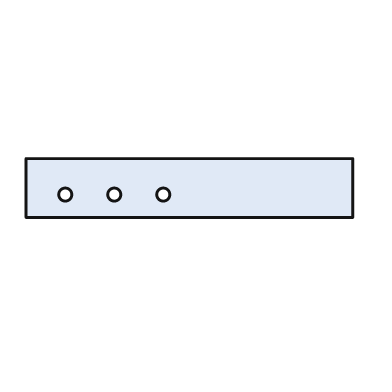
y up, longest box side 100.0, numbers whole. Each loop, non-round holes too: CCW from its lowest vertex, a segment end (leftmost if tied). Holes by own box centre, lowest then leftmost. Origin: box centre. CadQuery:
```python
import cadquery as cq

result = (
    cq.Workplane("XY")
    .moveTo(-50.0, -9.0)
    .lineTo(50.0, -9.0)
    .lineTo(50.0, 9.0)
    .lineTo(-50.0, 9.0)
    .close()
    .moveTo(-38.0, -2.0)
    .circle(2.0)
    .moveTo(-23.0, -2.0)
    .circle(2.0)
    .moveTo(-8.0, -2.0)
    .circle(2.0)
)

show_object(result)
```